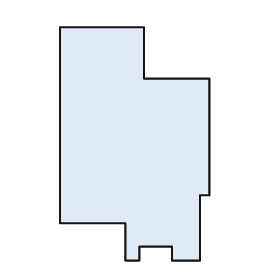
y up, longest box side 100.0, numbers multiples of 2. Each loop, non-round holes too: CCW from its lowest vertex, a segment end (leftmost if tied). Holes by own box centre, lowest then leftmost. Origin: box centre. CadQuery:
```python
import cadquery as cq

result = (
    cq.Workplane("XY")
    .moveTo(-4.0, -50.0)
    .lineTo(2.0, -50.0)
    .lineTo(2.0, -44.0)
    .lineTo(16.0, -44.0)
    .lineTo(16.0, -50.0)
    .lineTo(28.0, -50.0)
    .lineTo(28.0, -22.0)
    .lineTo(32.0, -22.0)
    .lineTo(32.0, 28.0)
    .lineTo(4.0, 28.0)
    .lineTo(4.0, 50.0)
    .lineTo(-32.0, 50.0)
    .lineTo(-32.0, -34.0)
    .lineTo(-4.0, -34.0)
    .close()
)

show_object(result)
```